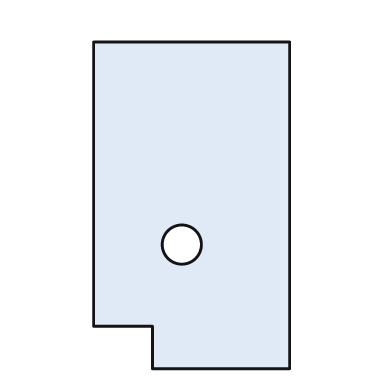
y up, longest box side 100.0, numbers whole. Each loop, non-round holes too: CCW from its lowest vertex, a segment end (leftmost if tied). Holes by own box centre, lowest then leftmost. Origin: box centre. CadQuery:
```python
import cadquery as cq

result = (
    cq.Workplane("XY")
    .moveTo(-12.0, -50.0)
    .lineTo(30.0, -50.0)
    .lineTo(30.0, 50.0)
    .lineTo(-30.0, 50.0)
    .lineTo(-30.0, -37.0)
    .lineTo(-12.0, -37.0)
    .close()
    .moveTo(-3.0, -12.0)
    .circle(6.0)
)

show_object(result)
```